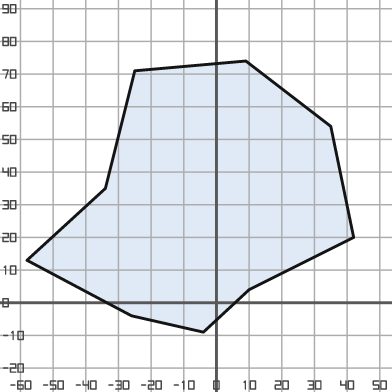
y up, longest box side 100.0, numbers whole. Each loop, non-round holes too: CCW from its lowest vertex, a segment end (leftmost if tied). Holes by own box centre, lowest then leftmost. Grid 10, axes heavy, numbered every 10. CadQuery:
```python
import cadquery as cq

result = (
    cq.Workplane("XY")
    .moveTo(-4.0, -9.0)
    .lineTo(10.0, 4.0)
    .lineTo(42.0, 20.0)
    .lineTo(35.0, 54.0)
    .lineTo(9.0, 74.0)
    .lineTo(-25.0, 71.0)
    .lineTo(-34.0, 35.0)
    .lineTo(-58.0, 13.0)
    .lineTo(-26.0, -4.0)
    .close()
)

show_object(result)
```